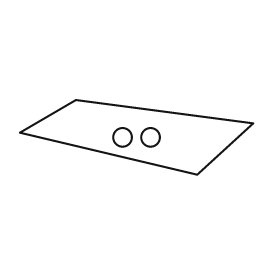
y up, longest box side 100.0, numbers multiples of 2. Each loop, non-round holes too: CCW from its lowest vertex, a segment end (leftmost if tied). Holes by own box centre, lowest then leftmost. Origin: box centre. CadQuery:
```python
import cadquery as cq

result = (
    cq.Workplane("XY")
    .moveTo(26.0, -16.0)
    .lineTo(50.0, 6.0)
    .lineTo(-26.0, 16.0)
    .lineTo(-50.0, 2.0)
    .close()
    .moveTo(-6.0, 0.0)
    .circle(4.0)
    .moveTo(6.0, 0.0)
    .circle(4.0)
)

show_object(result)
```